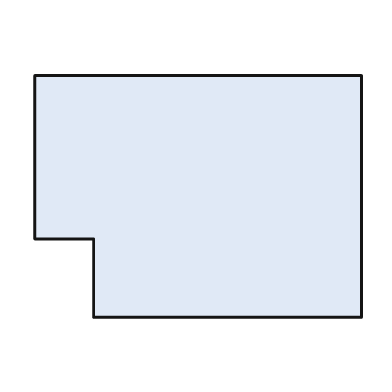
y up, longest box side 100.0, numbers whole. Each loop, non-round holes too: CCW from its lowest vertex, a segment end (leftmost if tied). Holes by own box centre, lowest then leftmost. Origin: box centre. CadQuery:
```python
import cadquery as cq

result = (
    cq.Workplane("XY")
    .moveTo(-32.0, -37.0)
    .lineTo(50.0, -37.0)
    .lineTo(50.0, 37.0)
    .lineTo(-50.0, 37.0)
    .lineTo(-50.0, -13.0)
    .lineTo(-32.0, -13.0)
    .close()
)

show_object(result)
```